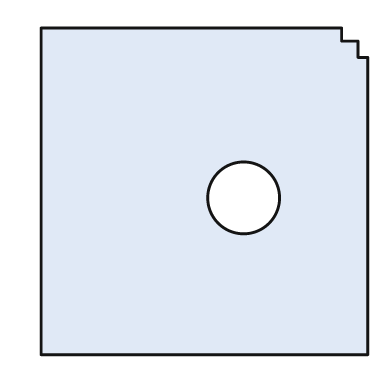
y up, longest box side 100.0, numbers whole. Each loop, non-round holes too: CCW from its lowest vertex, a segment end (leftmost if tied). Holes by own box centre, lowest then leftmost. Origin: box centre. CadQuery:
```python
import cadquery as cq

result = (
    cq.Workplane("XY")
    .moveTo(-50.0, -50.0)
    .lineTo(50.0, -50.0)
    .lineTo(50.0, 41.0)
    .lineTo(47.0, 41.0)
    .lineTo(47.0, 46.0)
    .lineTo(42.0, 46.0)
    .lineTo(42.0, 50.0)
    .lineTo(-50.0, 50.0)
    .close()
    .moveTo(12.0, -2.0)
    .circle(11.0)
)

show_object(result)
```